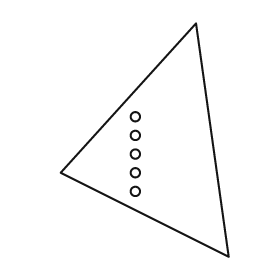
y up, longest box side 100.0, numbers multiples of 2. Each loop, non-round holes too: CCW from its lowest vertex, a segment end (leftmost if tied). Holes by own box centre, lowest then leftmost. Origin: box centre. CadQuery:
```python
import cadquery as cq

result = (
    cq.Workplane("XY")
    .moveTo(36.0, -50.0)
    .lineTo(22.0, 50.0)
    .lineTo(-36.0, -14.0)
    .close()
    .moveTo(-4.0, -22.0)
    .circle(2.0)
    .moveTo(-4.0, -14.0)
    .circle(2.0)
    .moveTo(-4.0, -6.0)
    .circle(2.0)
    .moveTo(-4.0, 2.0)
    .circle(2.0)
    .moveTo(-4.0, 10.0)
    .circle(2.0)
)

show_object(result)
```